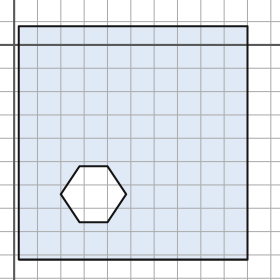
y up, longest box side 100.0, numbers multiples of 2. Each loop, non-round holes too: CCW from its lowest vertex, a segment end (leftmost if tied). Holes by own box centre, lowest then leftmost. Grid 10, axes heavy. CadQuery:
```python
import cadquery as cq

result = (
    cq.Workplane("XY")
    .moveTo(2.0, -92.0)
    .lineTo(100.0, -92.0)
    .lineTo(100.0, 8.0)
    .lineTo(2.0, 8.0)
    .close()
    .moveTo(28.0, -76.0)
    .lineTo(40.0, -76.0)
    .lineTo(48.0, -64.0)
    .lineTo(40.0, -52.0)
    .lineTo(28.0, -52.0)
    .lineTo(20.0, -64.0)
    .close()
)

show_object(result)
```